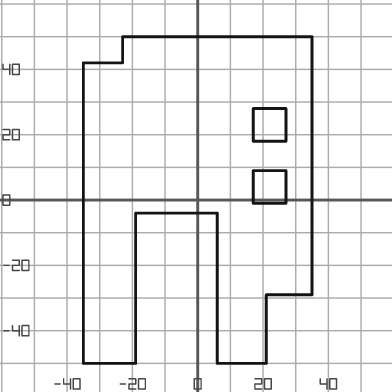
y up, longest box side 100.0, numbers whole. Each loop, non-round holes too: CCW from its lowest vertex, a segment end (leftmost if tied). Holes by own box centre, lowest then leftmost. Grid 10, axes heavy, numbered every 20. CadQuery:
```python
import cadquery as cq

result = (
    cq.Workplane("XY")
    .moveTo(-35.0, -50.0)
    .lineTo(-19.0, -50.0)
    .lineTo(-19.0, -4.0)
    .lineTo(6.0, -4.0)
    .lineTo(6.0, -50.0)
    .lineTo(21.0, -50.0)
    .lineTo(21.0, -29.0)
    .lineTo(35.0, -29.0)
    .lineTo(35.0, 50.0)
    .lineTo(-23.0, 50.0)
    .lineTo(-23.0, 42.0)
    .lineTo(-35.0, 42.0)
    .close()
    .moveTo(17.0, -1.0)
    .lineTo(27.0, -1.0)
    .lineTo(27.0, 9.0)
    .lineTo(17.0, 9.0)
    .close()
    .moveTo(17.0, 18.0)
    .lineTo(27.0, 18.0)
    .lineTo(27.0, 28.0)
    .lineTo(17.0, 28.0)
    .close()
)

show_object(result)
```